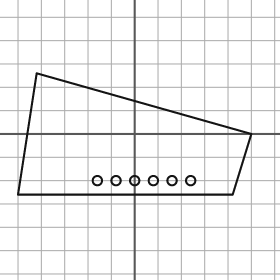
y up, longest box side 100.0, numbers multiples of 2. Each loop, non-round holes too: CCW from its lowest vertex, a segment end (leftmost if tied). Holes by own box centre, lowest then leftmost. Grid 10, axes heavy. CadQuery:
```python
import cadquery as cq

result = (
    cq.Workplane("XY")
    .moveTo(-50.0, -26.0)
    .lineTo(42.0, -26.0)
    .lineTo(50.0, 0.0)
    .lineTo(-42.0, 26.0)
    .close()
    .moveTo(-16.0, -20.0)
    .circle(2.0)
    .moveTo(-8.0, -20.0)
    .circle(2.0)
    .moveTo(0.0, -20.0)
    .circle(2.0)
    .moveTo(8.0, -20.0)
    .circle(2.0)
    .moveTo(16.0, -20.0)
    .circle(2.0)
    .moveTo(24.0, -20.0)
    .circle(2.0)
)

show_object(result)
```